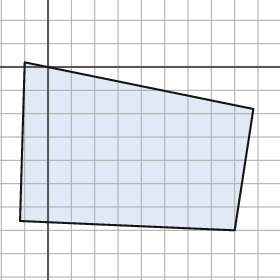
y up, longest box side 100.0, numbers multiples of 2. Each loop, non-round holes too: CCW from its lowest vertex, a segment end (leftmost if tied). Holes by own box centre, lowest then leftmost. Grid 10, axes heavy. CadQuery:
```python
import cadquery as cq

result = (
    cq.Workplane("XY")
    .moveTo(80.0, -70.0)
    .lineTo(88.0, -18.0)
    .lineTo(-10.0, 2.0)
    .lineTo(-12.0, -66.0)
    .close()
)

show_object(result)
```